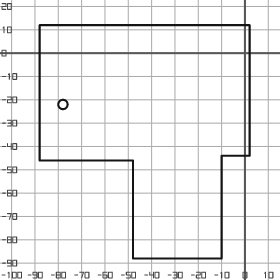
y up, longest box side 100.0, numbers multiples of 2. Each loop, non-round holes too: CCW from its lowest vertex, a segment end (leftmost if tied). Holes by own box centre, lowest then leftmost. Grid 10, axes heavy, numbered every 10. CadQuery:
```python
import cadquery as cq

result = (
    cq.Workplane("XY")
    .moveTo(-48.0, -88.0)
    .lineTo(-10.0, -88.0)
    .lineTo(-10.0, -44.0)
    .lineTo(2.0, -44.0)
    .lineTo(2.0, 12.0)
    .lineTo(-88.0, 12.0)
    .lineTo(-88.0, -46.0)
    .lineTo(-48.0, -46.0)
    .close()
    .moveTo(-78.0, -22.0)
    .circle(2.0)
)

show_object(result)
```